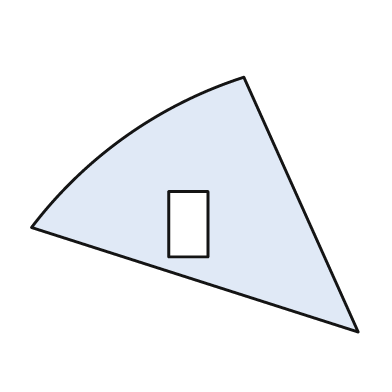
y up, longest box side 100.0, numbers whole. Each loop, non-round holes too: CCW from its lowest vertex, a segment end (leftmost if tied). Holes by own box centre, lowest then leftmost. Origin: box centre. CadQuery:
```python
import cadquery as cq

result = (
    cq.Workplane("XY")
    .moveTo(50.0, -39.0)
    .lineTo(15.0, 39.0)
    .threePointArc((-21.0, 21.0), (-50.0, -7.0))
    .close()
    .moveTo(-8.0, -16.0)
    .lineTo(4.0, -16.0)
    .lineTo(4.0, 4.0)
    .lineTo(-8.0, 4.0)
    .close()
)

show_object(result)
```